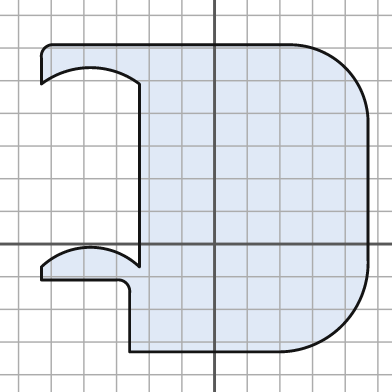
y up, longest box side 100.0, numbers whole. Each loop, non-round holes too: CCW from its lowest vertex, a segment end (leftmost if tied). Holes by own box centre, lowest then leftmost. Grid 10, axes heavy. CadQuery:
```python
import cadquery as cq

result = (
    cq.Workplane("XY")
    .moveTo(-26.0, -33.0)
    .lineTo(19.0, -33.0)
    .threePointArc((39.0, -25.0), (47.0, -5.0))
    .lineTo(47.0, 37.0)
    .threePointArc((40.0, 54.0), (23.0, 61.0))
    .lineTo(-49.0, 61.0)
    .threePointArc((-52.0, 60.0), (-53.0, 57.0))
    .lineTo(-53.0, 49.0)
    .threePointArc((-38.0, 54.0), (-23.0, 49.0))
    .lineTo(-23.0, -7.0)
    .threePointArc((-38.0, -1.0), (-53.0, -7.0))
    .lineTo(-53.0, -11.0)
    .lineTo(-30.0, -11.0)
    .threePointArc((-27.0, -12.0), (-26.0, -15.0))
    .close()
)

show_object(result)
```